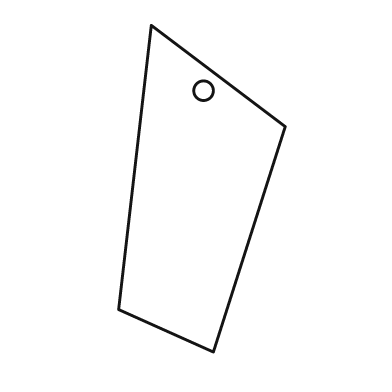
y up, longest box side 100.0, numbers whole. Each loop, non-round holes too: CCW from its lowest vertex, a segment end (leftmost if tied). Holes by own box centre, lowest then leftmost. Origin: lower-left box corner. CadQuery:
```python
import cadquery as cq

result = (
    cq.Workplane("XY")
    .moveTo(29.0, 0.0)
    .lineTo(51.0, 69.0)
    .lineTo(10.0, 100.0)
    .lineTo(0.0, 13.0)
    .close()
    .moveTo(26.0, 80.0)
    .circle(3.0)
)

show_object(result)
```